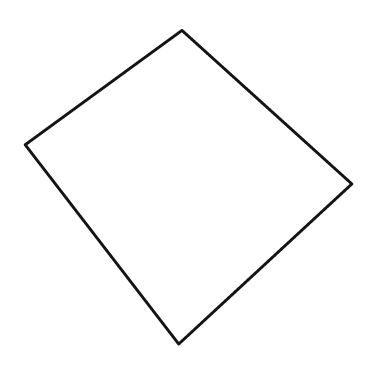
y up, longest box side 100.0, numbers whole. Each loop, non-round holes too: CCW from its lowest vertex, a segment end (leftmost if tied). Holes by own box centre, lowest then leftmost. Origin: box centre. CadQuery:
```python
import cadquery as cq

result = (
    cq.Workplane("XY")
    .moveTo(-3.0, -48.0)
    .lineTo(50.0, 1.0)
    .lineTo(-2.0, 48.0)
    .lineTo(-50.0, 13.0)
    .close()
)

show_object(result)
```